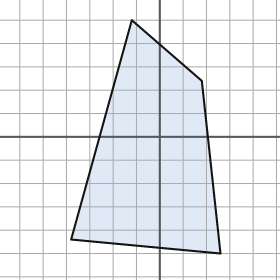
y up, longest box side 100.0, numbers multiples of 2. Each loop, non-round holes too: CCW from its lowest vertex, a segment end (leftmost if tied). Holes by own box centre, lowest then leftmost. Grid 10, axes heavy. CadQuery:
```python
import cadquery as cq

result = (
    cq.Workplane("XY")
    .moveTo(26.0, -50.0)
    .lineTo(18.0, 24.0)
    .lineTo(-12.0, 50.0)
    .lineTo(-38.0, -44.0)
    .close()
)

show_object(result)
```